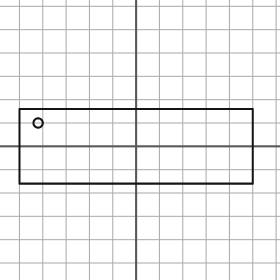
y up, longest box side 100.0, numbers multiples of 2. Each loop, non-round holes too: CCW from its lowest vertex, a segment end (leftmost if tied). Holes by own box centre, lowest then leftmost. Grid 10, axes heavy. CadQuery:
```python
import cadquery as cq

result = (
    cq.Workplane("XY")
    .moveTo(-50.0, -16.0)
    .lineTo(50.0, -16.0)
    .lineTo(50.0, 16.0)
    .lineTo(-50.0, 16.0)
    .close()
    .moveTo(-42.0, 10.0)
    .circle(2.0)
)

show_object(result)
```